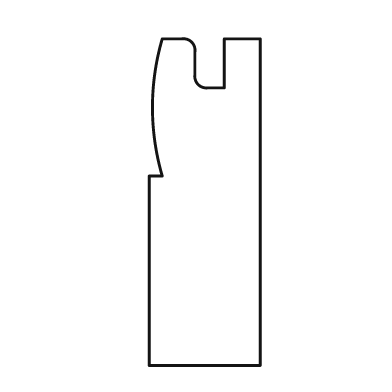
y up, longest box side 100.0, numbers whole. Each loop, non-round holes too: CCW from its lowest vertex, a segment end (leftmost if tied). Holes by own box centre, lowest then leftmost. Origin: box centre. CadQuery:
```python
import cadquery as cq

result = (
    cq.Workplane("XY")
    .moveTo(-17.0, -50.0)
    .lineTo(17.0, -50.0)
    .lineTo(17.0, 50.0)
    .lineTo(6.0, 50.0)
    .lineTo(6.0, 35.0)
    .lineTo(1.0, 35.0)
    .threePointArc((-2.0, 36.0), (-3.0, 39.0))
    .lineTo(-3.0, 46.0)
    .threePointArc((-4.0, 49.0), (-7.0, 50.0))
    .lineTo(-13.0, 50.0)
    .threePointArc((-16.0, 29.0), (-13.0, 8.0))
    .lineTo(-17.0, 8.0)
    .close()
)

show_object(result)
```